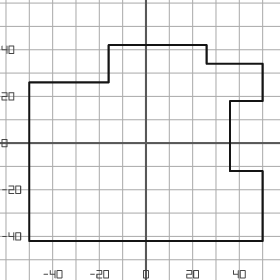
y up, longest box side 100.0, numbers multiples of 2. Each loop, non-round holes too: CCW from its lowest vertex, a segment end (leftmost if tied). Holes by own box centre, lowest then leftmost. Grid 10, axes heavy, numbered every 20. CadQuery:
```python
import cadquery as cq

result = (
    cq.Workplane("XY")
    .moveTo(-50.0, -42.0)
    .lineTo(50.0, -42.0)
    .lineTo(50.0, -12.0)
    .lineTo(36.0, -12.0)
    .lineTo(36.0, 18.0)
    .lineTo(50.0, 18.0)
    .lineTo(50.0, 34.0)
    .lineTo(26.0, 34.0)
    .lineTo(26.0, 42.0)
    .lineTo(-16.0, 42.0)
    .lineTo(-16.0, 26.0)
    .lineTo(-50.0, 26.0)
    .close()
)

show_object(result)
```